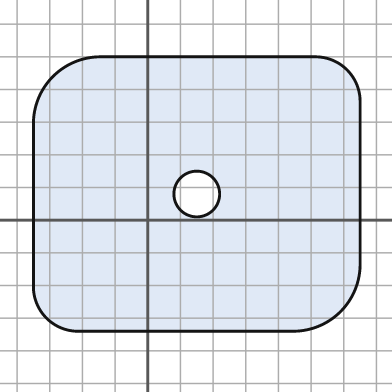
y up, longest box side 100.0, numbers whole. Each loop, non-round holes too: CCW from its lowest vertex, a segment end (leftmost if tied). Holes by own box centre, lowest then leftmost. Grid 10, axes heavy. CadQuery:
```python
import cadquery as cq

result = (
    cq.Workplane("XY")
    .moveTo(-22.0, -34.0)
    .lineTo(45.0, -34.0)
    .threePointArc((59.0, -28.0), (65.0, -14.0))
    .lineTo(65.0, 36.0)
    .threePointArc((61.0, 46.0), (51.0, 50.0))
    .lineTo(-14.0, 50.0)
    .threePointArc((-29.0, 44.0), (-35.0, 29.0))
    .lineTo(-35.0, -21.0)
    .threePointArc((-31.0, -30.0), (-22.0, -34.0))
    .close()
    .moveTo(15.0, 8.0)
    .circle(7.0)
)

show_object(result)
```